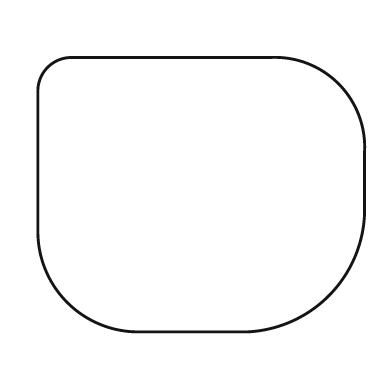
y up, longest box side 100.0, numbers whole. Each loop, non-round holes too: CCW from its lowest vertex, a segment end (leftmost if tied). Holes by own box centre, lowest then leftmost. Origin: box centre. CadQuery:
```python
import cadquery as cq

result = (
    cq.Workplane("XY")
    .moveTo(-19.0, -42.0)
    .lineTo(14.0, -42.0)
    .threePointArc((39.0, -31.0), (50.0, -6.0))
    .lineTo(50.0, 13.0)
    .threePointArc((42.0, 34.0), (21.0, 42.0))
    .lineTo(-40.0, 42.0)
    .threePointArc((-47.0, 39.0), (-50.0, 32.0))
    .lineTo(-50.0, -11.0)
    .threePointArc((-41.0, -33.0), (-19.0, -42.0))
    .close()
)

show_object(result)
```